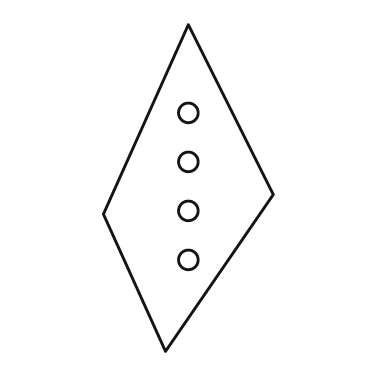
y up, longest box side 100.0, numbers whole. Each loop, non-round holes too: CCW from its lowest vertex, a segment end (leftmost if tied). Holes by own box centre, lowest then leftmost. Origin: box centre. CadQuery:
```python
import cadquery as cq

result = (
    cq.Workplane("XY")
    .moveTo(-7.0, -50.0)
    .lineTo(26.0, -2.0)
    .lineTo(0.0, 50.0)
    .lineTo(-26.0, -8.0)
    .close()
    .moveTo(0.0, -22.0)
    .circle(3.0)
    .moveTo(0.0, -7.0)
    .circle(3.0)
    .moveTo(0.0, 8.0)
    .circle(3.0)
    .moveTo(0.0, 23.0)
    .circle(3.0)
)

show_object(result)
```